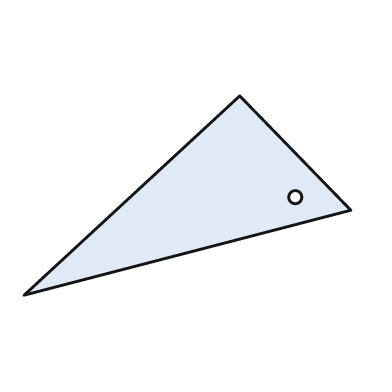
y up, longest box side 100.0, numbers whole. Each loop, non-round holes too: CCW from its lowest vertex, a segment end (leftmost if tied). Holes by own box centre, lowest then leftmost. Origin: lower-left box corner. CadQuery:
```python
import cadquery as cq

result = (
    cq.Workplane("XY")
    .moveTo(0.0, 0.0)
    .lineTo(100.0, 26.0)
    .lineTo(66.0, 61.0)
    .close()
    .moveTo(83.0, 30.0)
    .circle(2.0)
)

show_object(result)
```